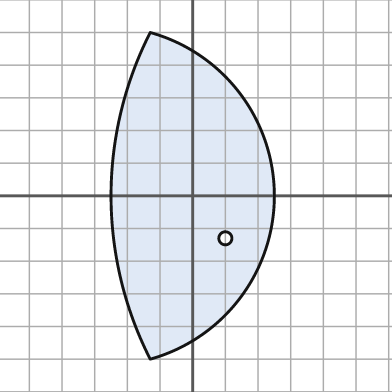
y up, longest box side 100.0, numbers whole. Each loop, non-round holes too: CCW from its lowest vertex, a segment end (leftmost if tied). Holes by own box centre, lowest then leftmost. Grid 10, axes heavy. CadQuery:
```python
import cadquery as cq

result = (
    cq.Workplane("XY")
    .moveTo(-13.0, -50.0)
    .threePointArc((25.0, 0.0), (-13.0, 50.0))
    .threePointArc((-25.0, 0.0), (-13.0, -50.0))
    .close()
    .moveTo(10.0, -13.0)
    .circle(2.0)
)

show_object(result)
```